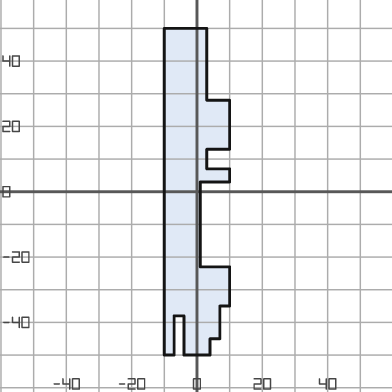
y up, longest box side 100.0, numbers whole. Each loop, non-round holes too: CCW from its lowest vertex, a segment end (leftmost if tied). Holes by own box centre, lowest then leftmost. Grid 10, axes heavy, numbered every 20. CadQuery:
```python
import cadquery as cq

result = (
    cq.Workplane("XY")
    .moveTo(-10.0, -50.0)
    .lineTo(-7.0, -50.0)
    .lineTo(-7.0, -38.0)
    .lineTo(-4.0, -38.0)
    .lineTo(-4.0, -50.0)
    .lineTo(4.0, -50.0)
    .lineTo(4.0, -45.0)
    .lineTo(7.0, -45.0)
    .lineTo(7.0, -35.0)
    .lineTo(10.0, -35.0)
    .lineTo(10.0, -23.0)
    .lineTo(1.0, -23.0)
    .lineTo(1.0, 3.0)
    .lineTo(10.0, 3.0)
    .lineTo(10.0, 7.0)
    .lineTo(3.0, 7.0)
    .lineTo(3.0, 13.0)
    .lineTo(10.0, 13.0)
    .lineTo(10.0, 28.0)
    .lineTo(3.0, 28.0)
    .lineTo(3.0, 50.0)
    .lineTo(-10.0, 50.0)
    .close()
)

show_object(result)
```